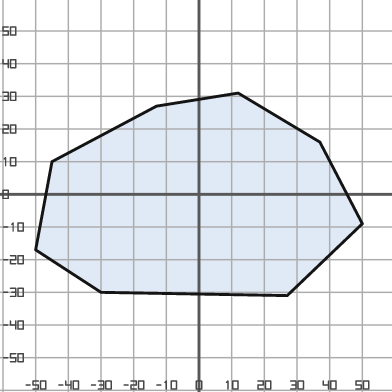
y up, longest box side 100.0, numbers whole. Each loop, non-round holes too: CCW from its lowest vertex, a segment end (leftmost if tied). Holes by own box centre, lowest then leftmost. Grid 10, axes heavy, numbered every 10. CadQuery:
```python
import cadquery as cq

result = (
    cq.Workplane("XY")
    .moveTo(27.0, -31.0)
    .lineTo(50.0, -9.0)
    .lineTo(37.0, 16.0)
    .lineTo(12.0, 31.0)
    .lineTo(-13.0, 27.0)
    .lineTo(-45.0, 10.0)
    .lineTo(-50.0, -17.0)
    .lineTo(-30.0, -30.0)
    .close()
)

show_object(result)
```